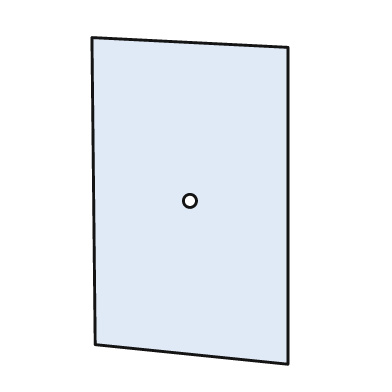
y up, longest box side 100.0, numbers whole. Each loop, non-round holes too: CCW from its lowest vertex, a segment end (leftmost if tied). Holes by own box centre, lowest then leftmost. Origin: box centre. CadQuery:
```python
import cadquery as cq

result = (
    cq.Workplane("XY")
    .moveTo(30.0, -50.0)
    .lineTo(30.0, 47.0)
    .lineTo(-30.0, 50.0)
    .lineTo(-29.0, -44.0)
    .close()
    .moveTo(0.0, 0.0)
    .circle(2.0)
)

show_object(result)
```